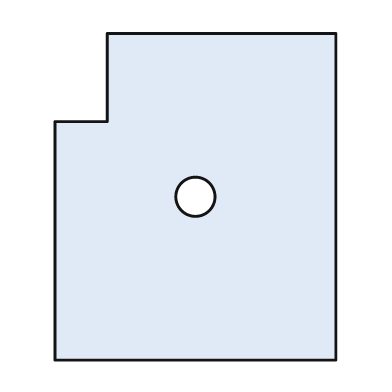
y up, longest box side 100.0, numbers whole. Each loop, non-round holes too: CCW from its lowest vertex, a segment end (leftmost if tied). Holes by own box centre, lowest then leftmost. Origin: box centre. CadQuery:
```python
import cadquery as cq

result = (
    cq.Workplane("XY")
    .moveTo(-43.0, -50.0)
    .lineTo(43.0, -50.0)
    .lineTo(43.0, 50.0)
    .lineTo(-27.0, 50.0)
    .lineTo(-27.0, 23.0)
    .lineTo(-43.0, 23.0)
    .close()
    .moveTo(0.0, 0.0)
    .circle(6.0)
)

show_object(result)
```